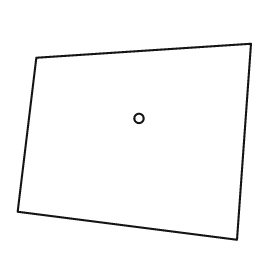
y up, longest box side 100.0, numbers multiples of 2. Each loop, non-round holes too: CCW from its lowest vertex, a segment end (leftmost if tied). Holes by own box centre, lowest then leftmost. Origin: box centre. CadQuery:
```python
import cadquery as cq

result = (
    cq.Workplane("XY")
    .moveTo(44.0, -42.0)
    .lineTo(50.0, 42.0)
    .lineTo(-42.0, 36.0)
    .lineTo(-50.0, -30.0)
    .close()
    .moveTo(2.0, 10.0)
    .circle(2.0)
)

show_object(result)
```